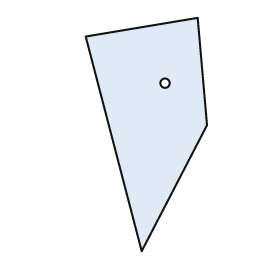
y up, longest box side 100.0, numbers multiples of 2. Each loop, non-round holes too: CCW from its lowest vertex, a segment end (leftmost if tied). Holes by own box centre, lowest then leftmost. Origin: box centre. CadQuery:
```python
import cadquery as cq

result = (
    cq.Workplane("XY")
    .moveTo(-2.0, -50.0)
    .lineTo(26.0, 4.0)
    .lineTo(22.0, 50.0)
    .lineTo(-26.0, 42.0)
    .close()
    .moveTo(8.0, 22.0)
    .circle(2.0)
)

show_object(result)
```